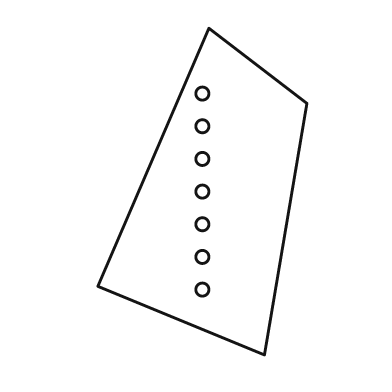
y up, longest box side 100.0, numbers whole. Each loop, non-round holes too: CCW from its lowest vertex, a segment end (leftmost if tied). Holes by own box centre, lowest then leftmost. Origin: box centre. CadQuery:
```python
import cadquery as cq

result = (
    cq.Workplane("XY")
    .moveTo(19.0, -50.0)
    .lineTo(32.0, 27.0)
    .lineTo(2.0, 50.0)
    .lineTo(-32.0, -29.0)
    .close()
    .moveTo(0.0, -30.0)
    .circle(2.0)
    .moveTo(0.0, -20.0)
    .circle(2.0)
    .moveTo(0.0, -10.0)
    .circle(2.0)
    .moveTo(0.0, 0.0)
    .circle(2.0)
    .moveTo(0.0, 10.0)
    .circle(2.0)
    .moveTo(0.0, 20.0)
    .circle(2.0)
    .moveTo(0.0, 30.0)
    .circle(2.0)
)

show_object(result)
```